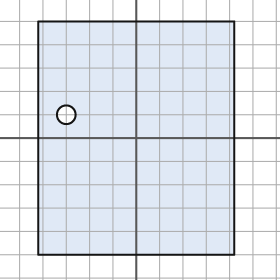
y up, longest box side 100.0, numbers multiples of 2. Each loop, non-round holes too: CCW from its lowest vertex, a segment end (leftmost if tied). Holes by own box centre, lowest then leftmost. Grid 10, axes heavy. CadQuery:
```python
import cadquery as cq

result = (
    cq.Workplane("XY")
    .moveTo(-42.0, -50.0)
    .lineTo(42.0, -50.0)
    .lineTo(42.0, 50.0)
    .lineTo(-42.0, 50.0)
    .close()
    .moveTo(-30.0, 10.0)
    .circle(4.0)
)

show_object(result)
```